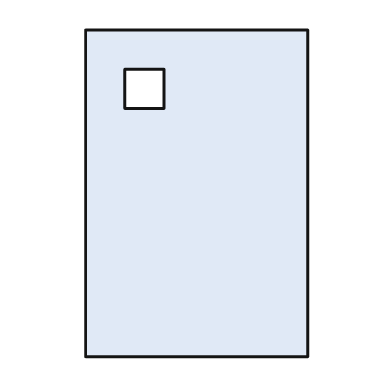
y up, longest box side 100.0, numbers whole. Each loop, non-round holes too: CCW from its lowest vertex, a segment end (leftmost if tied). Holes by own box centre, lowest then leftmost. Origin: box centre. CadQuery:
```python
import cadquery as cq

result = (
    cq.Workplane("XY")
    .moveTo(-34.0, -50.0)
    .lineTo(34.0, -50.0)
    .lineTo(34.0, 50.0)
    .lineTo(-34.0, 50.0)
    .close()
    .moveTo(-22.0, 26.0)
    .lineTo(-10.0, 26.0)
    .lineTo(-10.0, 38.0)
    .lineTo(-22.0, 38.0)
    .close()
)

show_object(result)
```